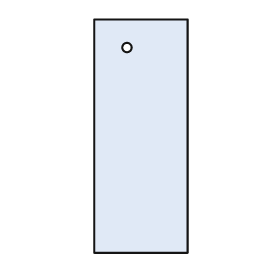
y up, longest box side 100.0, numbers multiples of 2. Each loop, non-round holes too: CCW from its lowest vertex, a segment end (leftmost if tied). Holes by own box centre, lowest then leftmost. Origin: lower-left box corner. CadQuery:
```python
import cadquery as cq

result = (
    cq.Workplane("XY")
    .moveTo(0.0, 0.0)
    .lineTo(40.0, 0.0)
    .lineTo(40.0, 100.0)
    .lineTo(0.0, 100.0)
    .close()
    .moveTo(14.0, 88.0)
    .circle(2.0)
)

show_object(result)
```